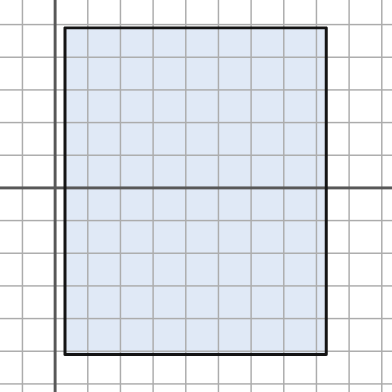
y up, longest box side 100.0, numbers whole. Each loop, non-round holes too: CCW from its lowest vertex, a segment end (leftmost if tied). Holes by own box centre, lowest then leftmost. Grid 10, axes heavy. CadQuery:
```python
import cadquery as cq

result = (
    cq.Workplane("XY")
    .moveTo(3.0, -51.0)
    .lineTo(83.0, -51.0)
    .lineTo(83.0, 49.0)
    .lineTo(3.0, 49.0)
    .close()
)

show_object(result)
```